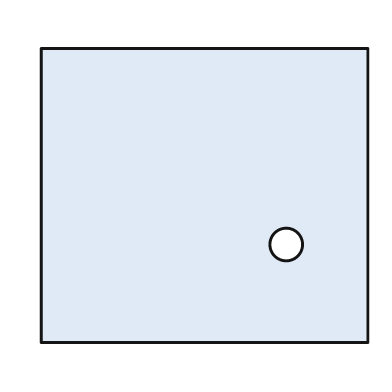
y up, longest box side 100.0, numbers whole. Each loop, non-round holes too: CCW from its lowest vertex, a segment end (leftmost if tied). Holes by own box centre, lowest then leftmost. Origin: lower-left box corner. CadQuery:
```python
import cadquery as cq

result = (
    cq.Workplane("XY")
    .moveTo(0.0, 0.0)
    .lineTo(100.0, 0.0)
    .lineTo(100.0, 90.0)
    .lineTo(0.0, 90.0)
    .close()
    .moveTo(75.0, 30.0)
    .circle(5.0)
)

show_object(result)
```